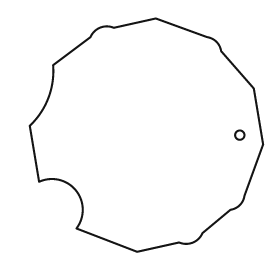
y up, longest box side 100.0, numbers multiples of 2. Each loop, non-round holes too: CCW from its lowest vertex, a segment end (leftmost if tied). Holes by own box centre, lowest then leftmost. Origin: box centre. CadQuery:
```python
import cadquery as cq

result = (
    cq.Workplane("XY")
    .moveTo(-4.0, -50.0)
    .lineTo(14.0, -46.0)
    .threePointArc((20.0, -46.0), (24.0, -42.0))
    .lineTo(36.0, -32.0)
    .threePointArc((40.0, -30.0), (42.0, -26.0))
    .lineTo(50.0, -4.0)
    .lineTo(46.0, 20.0)
    .lineTo(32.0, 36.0)
    .threePointArc((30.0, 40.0), (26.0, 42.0))
    .lineTo(4.0, 50.0)
    .lineTo(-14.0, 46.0)
    .threePointArc((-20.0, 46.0), (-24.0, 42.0))
    .lineTo(-40.0, 30.0)
    .threePointArc((-42.0, 16.0), (-50.0, 4.0))
    .lineTo(-46.0, -20.0)
    .threePointArc((-30.0, -24.0), (-30.0, -40.0))
    .close()
    .moveTo(40.0, 0.0)
    .circle(2.0)
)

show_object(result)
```